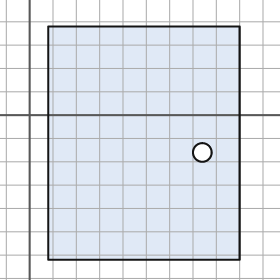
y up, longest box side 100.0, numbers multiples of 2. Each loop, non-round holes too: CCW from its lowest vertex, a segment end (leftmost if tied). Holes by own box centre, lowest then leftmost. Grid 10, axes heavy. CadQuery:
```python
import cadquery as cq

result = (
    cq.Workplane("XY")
    .moveTo(8.0, -62.0)
    .lineTo(90.0, -62.0)
    .lineTo(90.0, 38.0)
    .lineTo(8.0, 38.0)
    .close()
    .moveTo(74.0, -16.0)
    .circle(4.0)
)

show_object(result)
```